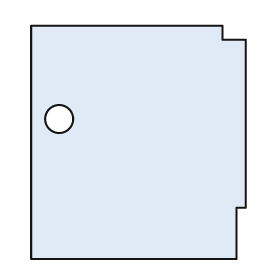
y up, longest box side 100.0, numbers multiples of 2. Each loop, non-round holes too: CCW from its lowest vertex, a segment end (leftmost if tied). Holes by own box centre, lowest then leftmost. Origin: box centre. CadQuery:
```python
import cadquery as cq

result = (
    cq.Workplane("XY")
    .moveTo(-46.0, -50.0)
    .lineTo(42.0, -50.0)
    .lineTo(42.0, -28.0)
    .lineTo(46.0, -28.0)
    .lineTo(46.0, 44.0)
    .lineTo(36.0, 44.0)
    .lineTo(36.0, 50.0)
    .lineTo(-46.0, 50.0)
    .close()
    .moveTo(-34.0, 10.0)
    .circle(6.0)
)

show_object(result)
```